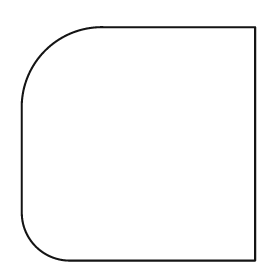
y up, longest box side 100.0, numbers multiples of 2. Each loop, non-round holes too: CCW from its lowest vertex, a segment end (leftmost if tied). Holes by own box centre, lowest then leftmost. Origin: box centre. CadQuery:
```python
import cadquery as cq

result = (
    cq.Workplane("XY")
    .moveTo(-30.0, -50.0)
    .lineTo(50.0, -50.0)
    .lineTo(50.0, 50.0)
    .lineTo(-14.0, 50.0)
    .threePointArc((-40.0, 40.0), (-50.0, 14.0))
    .lineTo(-50.0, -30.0)
    .threePointArc((-44.0, -44.0), (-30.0, -50.0))
    .close()
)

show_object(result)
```